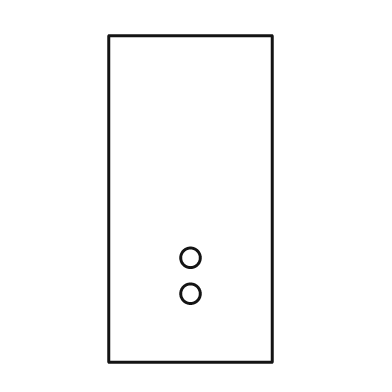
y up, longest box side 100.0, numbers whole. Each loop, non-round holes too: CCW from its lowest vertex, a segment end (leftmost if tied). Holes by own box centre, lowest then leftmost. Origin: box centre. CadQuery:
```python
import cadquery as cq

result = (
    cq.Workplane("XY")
    .moveTo(-25.0, -50.0)
    .lineTo(25.0, -50.0)
    .lineTo(25.0, 50.0)
    .lineTo(-25.0, 50.0)
    .close()
    .moveTo(0.0, -29.0)
    .circle(3.0)
    .moveTo(0.0, -18.0)
    .circle(3.0)
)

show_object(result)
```